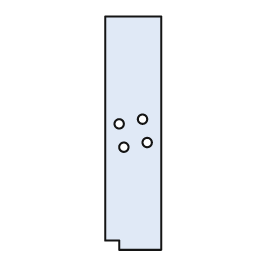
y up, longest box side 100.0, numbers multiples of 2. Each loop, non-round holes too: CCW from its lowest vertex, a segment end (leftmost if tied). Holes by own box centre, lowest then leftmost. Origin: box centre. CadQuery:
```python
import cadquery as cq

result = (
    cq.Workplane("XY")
    .moveTo(-6.0, -50.0)
    .lineTo(12.0, -50.0)
    .lineTo(12.0, 50.0)
    .lineTo(-12.0, 50.0)
    .lineTo(-12.0, -46.0)
    .lineTo(-6.0, -46.0)
    .close()
    .moveTo(-4.0, -6.0)
    .circle(2.0)
    .moveTo(6.0, -4.0)
    .circle(2.0)
    .moveTo(-6.0, 4.0)
    .circle(2.0)
    .moveTo(4.0, 6.0)
    .circle(2.0)
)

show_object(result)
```